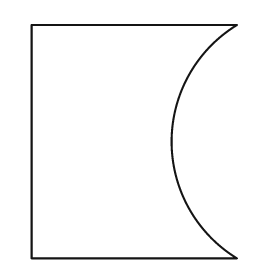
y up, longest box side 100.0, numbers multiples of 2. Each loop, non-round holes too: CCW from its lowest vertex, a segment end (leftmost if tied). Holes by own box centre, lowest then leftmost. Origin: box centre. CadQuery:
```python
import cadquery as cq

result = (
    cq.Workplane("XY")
    .moveTo(-44.0, -50.0)
    .lineTo(44.0, -50.0)
    .threePointArc((16.0, 0.0), (44.0, 50.0))
    .lineTo(-44.0, 50.0)
    .close()
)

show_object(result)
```